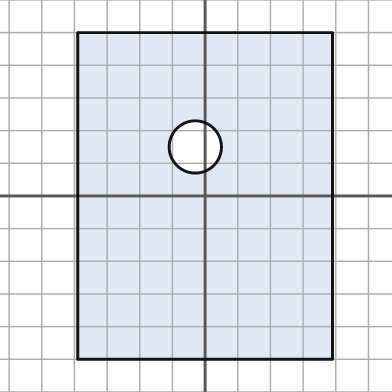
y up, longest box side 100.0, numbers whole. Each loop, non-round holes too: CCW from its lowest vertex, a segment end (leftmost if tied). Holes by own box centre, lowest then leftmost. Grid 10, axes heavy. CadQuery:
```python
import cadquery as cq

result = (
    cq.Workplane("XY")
    .moveTo(-39.0, -50.0)
    .lineTo(39.0, -50.0)
    .lineTo(39.0, 50.0)
    .lineTo(-39.0, 50.0)
    .close()
    .moveTo(-3.0, 15.0)
    .circle(8.0)
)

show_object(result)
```